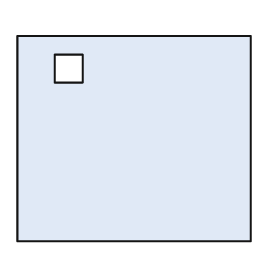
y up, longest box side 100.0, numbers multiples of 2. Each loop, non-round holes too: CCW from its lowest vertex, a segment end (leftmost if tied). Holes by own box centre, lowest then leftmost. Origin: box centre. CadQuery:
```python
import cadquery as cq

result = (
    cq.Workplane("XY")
    .moveTo(-50.0, -44.0)
    .lineTo(50.0, -44.0)
    .lineTo(50.0, 44.0)
    .lineTo(-50.0, 44.0)
    .close()
    .moveTo(-34.0, 24.0)
    .lineTo(-22.0, 24.0)
    .lineTo(-22.0, 36.0)
    .lineTo(-34.0, 36.0)
    .close()
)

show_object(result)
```